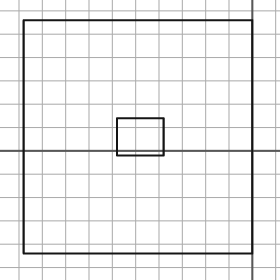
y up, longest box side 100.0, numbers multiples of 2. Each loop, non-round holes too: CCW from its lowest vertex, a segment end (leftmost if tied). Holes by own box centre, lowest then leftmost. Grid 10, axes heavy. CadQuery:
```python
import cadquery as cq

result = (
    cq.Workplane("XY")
    .moveTo(-98.0, -44.0)
    .lineTo(0.0, -44.0)
    .lineTo(0.0, 56.0)
    .lineTo(-98.0, 56.0)
    .close()
    .moveTo(-58.0, -2.0)
    .lineTo(-38.0, -2.0)
    .lineTo(-38.0, 14.0)
    .lineTo(-58.0, 14.0)
    .close()
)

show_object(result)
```